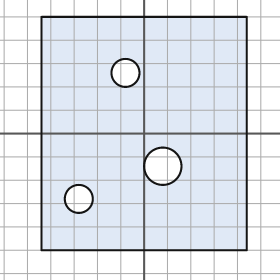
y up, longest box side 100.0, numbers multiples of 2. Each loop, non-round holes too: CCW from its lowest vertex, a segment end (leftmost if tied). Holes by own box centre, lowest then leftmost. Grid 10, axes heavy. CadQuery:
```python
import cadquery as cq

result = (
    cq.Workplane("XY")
    .moveTo(-44.0, -50.0)
    .lineTo(44.0, -50.0)
    .lineTo(44.0, 50.0)
    .lineTo(-44.0, 50.0)
    .close()
    .moveTo(-28.0, -28.0)
    .circle(6.0)
    .moveTo(8.0, -14.0)
    .circle(8.0)
    .moveTo(-8.0, 26.0)
    .circle(6.0)
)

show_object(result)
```